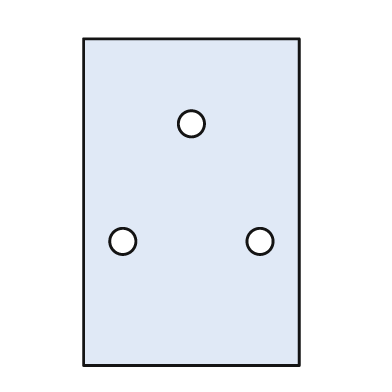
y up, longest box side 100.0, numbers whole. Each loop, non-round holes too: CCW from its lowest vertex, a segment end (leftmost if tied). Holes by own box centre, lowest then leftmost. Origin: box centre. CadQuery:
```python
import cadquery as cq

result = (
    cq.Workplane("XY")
    .moveTo(-33.0, -50.0)
    .lineTo(33.0, -50.0)
    .lineTo(33.0, 50.0)
    .lineTo(-33.0, 50.0)
    .close()
    .moveTo(-21.0, -12.0)
    .circle(4.0)
    .moveTo(21.0, -12.0)
    .circle(4.0)
    .moveTo(0.0, 24.0)
    .circle(4.0)
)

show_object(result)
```